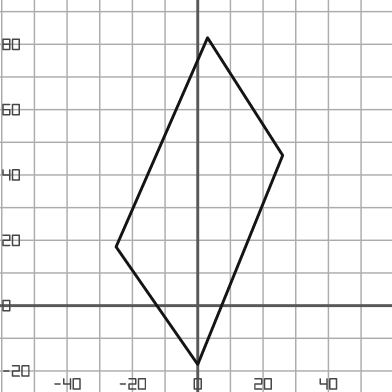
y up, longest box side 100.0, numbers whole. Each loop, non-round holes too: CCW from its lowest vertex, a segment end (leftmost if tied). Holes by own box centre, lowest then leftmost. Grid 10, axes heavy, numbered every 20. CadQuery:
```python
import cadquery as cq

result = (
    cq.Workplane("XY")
    .moveTo(0.0, -18.0)
    .lineTo(26.0, 46.0)
    .lineTo(3.0, 82.0)
    .lineTo(-25.0, 18.0)
    .close()
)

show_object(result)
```